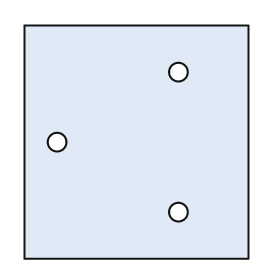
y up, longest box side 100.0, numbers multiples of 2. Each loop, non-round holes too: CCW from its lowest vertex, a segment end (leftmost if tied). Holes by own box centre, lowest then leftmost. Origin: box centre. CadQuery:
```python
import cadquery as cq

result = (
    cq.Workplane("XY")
    .moveTo(-48.0, -50.0)
    .lineTo(48.0, -50.0)
    .lineTo(48.0, 50.0)
    .lineTo(-48.0, 50.0)
    .close()
    .moveTo(18.0, -30.0)
    .circle(4.0)
    .moveTo(-34.0, 0.0)
    .circle(4.0)
    .moveTo(18.0, 30.0)
    .circle(4.0)
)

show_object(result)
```